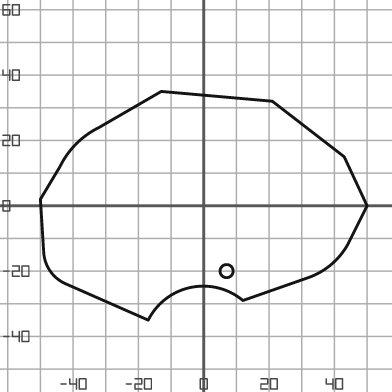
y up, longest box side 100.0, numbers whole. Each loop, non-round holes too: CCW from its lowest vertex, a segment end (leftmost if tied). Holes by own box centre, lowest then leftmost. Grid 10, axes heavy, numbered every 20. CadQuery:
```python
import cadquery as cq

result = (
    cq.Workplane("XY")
    .moveTo(-17.0, -35.0)
    .threePointArc((-4.0, -25.0), (12.0, -29.0))
    .lineTo(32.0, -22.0)
    .threePointArc((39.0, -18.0), (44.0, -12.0))
    .lineTo(50.0, 0.0)
    .lineTo(43.0, 15.0)
    .lineTo(21.0, 32.0)
    .lineTo(-13.0, 35.0)
    .lineTo(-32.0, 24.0)
    .threePointArc((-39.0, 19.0), (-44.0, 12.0))
    .lineTo(-50.0, 2.0)
    .lineTo(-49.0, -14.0)
    .threePointArc((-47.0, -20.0), (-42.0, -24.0))
    .close()
    .moveTo(7.0, -20.0)
    .circle(2.0)
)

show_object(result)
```